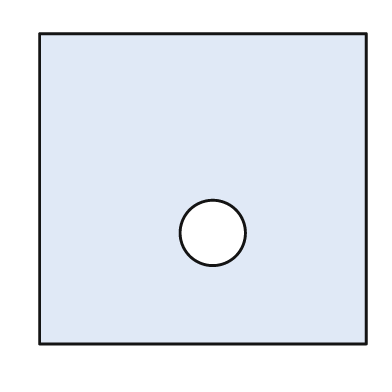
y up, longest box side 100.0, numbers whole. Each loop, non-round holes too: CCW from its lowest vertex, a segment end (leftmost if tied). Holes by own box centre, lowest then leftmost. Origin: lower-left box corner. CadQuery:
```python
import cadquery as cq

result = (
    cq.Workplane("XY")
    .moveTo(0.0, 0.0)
    .lineTo(100.0, 0.0)
    .lineTo(100.0, 95.0)
    .lineTo(0.0, 95.0)
    .close()
    .moveTo(53.0, 34.0)
    .circle(10.0)
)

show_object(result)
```